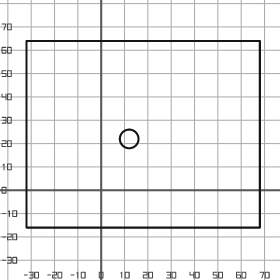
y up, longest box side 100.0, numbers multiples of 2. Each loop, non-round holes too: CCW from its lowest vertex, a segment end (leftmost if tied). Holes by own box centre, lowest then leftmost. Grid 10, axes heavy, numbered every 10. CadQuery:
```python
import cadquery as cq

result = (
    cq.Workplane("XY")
    .moveTo(-32.0, -16.0)
    .lineTo(68.0, -16.0)
    .lineTo(68.0, 64.0)
    .lineTo(-32.0, 64.0)
    .close()
    .moveTo(12.0, 22.0)
    .circle(4.0)
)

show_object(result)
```